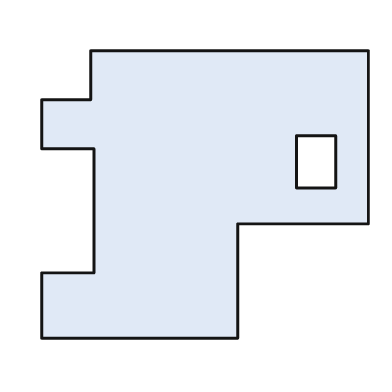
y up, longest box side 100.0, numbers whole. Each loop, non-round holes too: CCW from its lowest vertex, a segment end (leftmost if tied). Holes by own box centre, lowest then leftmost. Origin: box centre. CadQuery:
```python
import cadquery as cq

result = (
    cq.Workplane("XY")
    .moveTo(-50.0, -44.0)
    .lineTo(10.0, -44.0)
    .lineTo(10.0, -9.0)
    .lineTo(50.0, -9.0)
    .lineTo(50.0, 44.0)
    .lineTo(-35.0, 44.0)
    .lineTo(-35.0, 29.0)
    .lineTo(-50.0, 29.0)
    .lineTo(-50.0, 14.0)
    .lineTo(-34.0, 14.0)
    .lineTo(-34.0, -24.0)
    .lineTo(-50.0, -24.0)
    .close()
    .moveTo(28.0, 2.0)
    .lineTo(40.0, 2.0)
    .lineTo(40.0, 18.0)
    .lineTo(28.0, 18.0)
    .close()
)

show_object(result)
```